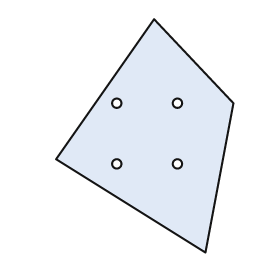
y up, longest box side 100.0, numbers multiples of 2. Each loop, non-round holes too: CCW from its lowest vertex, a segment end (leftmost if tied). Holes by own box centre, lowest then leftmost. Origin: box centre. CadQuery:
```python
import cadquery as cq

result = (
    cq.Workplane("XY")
    .moveTo(26.0, -50.0)
    .lineTo(38.0, 14.0)
    .lineTo(4.0, 50.0)
    .lineTo(-38.0, -10.0)
    .close()
    .moveTo(-12.0, -12.0)
    .circle(2.0)
    .moveTo(14.0, -12.0)
    .circle(2.0)
    .moveTo(-12.0, 14.0)
    .circle(2.0)
    .moveTo(14.0, 14.0)
    .circle(2.0)
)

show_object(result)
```